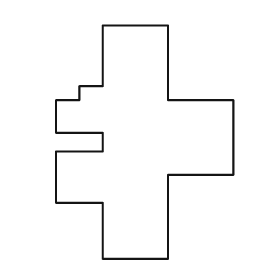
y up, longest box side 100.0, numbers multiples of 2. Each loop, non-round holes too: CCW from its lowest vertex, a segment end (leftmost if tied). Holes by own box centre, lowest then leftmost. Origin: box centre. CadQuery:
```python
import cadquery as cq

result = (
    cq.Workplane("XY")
    .moveTo(-18.0, -50.0)
    .lineTo(10.0, -50.0)
    .lineTo(10.0, -14.0)
    .lineTo(38.0, -14.0)
    .lineTo(38.0, 18.0)
    .lineTo(10.0, 18.0)
    .lineTo(10.0, 50.0)
    .lineTo(-18.0, 50.0)
    .lineTo(-18.0, 24.0)
    .lineTo(-28.0, 24.0)
    .lineTo(-28.0, 18.0)
    .lineTo(-38.0, 18.0)
    .lineTo(-38.0, 4.0)
    .lineTo(-18.0, 4.0)
    .lineTo(-18.0, -4.0)
    .lineTo(-38.0, -4.0)
    .lineTo(-38.0, -26.0)
    .lineTo(-18.0, -26.0)
    .close()
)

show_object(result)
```